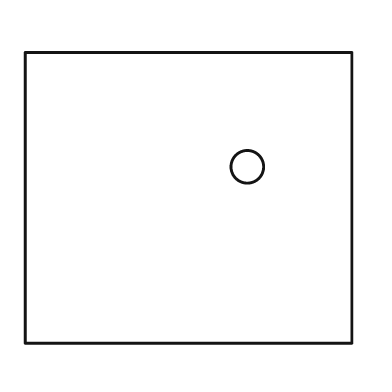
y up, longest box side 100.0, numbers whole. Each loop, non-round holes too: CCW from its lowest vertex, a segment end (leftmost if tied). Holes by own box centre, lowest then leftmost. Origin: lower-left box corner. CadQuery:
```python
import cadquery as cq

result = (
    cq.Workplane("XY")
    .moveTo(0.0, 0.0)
    .lineTo(100.0, 0.0)
    .lineTo(100.0, 89.0)
    .lineTo(0.0, 89.0)
    .close()
    .moveTo(68.0, 54.0)
    .circle(5.0)
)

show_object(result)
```